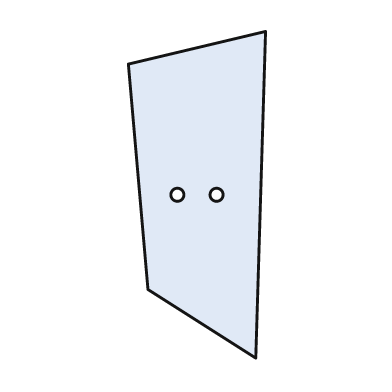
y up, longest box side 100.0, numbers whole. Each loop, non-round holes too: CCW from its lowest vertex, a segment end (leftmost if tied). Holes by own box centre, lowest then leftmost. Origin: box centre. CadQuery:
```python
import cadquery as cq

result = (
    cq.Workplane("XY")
    .moveTo(18.0, -50.0)
    .lineTo(21.0, 50.0)
    .lineTo(-21.0, 40.0)
    .lineTo(-15.0, -29.0)
    .close()
    .moveTo(-6.0, 0.0)
    .circle(2.0)
    .moveTo(6.0, 0.0)
    .circle(2.0)
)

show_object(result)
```